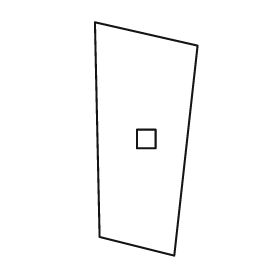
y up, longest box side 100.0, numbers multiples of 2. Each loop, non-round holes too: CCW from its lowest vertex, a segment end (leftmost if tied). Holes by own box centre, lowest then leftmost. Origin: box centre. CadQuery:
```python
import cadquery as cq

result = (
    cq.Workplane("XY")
    .moveTo(12.0, -50.0)
    .lineTo(22.0, 40.0)
    .lineTo(-22.0, 50.0)
    .lineTo(-20.0, -42.0)
    .close()
    .moveTo(-4.0, -4.0)
    .lineTo(4.0, -4.0)
    .lineTo(4.0, 4.0)
    .lineTo(-4.0, 4.0)
    .close()
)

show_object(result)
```